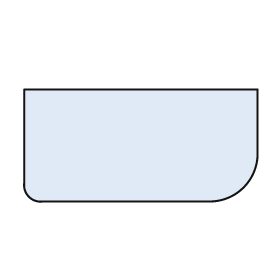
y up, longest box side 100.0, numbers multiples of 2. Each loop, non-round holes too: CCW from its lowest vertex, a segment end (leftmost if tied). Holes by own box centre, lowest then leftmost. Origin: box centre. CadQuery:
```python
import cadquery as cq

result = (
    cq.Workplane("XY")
    .moveTo(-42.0, -24.0)
    .lineTo(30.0, -24.0)
    .threePointArc((44.0, -18.0), (50.0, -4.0))
    .lineTo(50.0, 24.0)
    .lineTo(-50.0, 24.0)
    .lineTo(-50.0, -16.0)
    .threePointArc((-48.0, -22.0), (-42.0, -24.0))
    .close()
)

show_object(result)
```